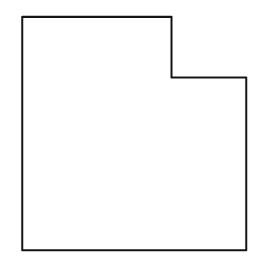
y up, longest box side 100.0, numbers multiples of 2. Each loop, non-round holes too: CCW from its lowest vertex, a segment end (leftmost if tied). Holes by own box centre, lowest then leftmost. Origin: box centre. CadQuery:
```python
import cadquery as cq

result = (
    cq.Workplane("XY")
    .moveTo(-48.0, -50.0)
    .lineTo(48.0, -50.0)
    .lineTo(48.0, 24.0)
    .lineTo(16.0, 24.0)
    .lineTo(16.0, 50.0)
    .lineTo(-48.0, 50.0)
    .close()
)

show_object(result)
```